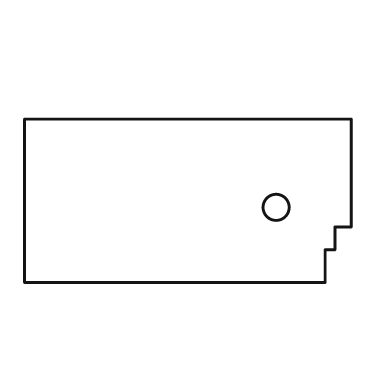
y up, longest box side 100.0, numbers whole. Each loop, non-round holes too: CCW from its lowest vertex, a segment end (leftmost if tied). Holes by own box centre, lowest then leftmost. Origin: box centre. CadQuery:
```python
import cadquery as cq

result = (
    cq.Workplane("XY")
    .moveTo(-50.0, -25.0)
    .lineTo(42.0, -25.0)
    .lineTo(42.0, -15.0)
    .lineTo(45.0, -15.0)
    .lineTo(45.0, -8.0)
    .lineTo(50.0, -8.0)
    .lineTo(50.0, 25.0)
    .lineTo(-50.0, 25.0)
    .close()
    .moveTo(27.0, -2.0)
    .circle(4.0)
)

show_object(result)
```